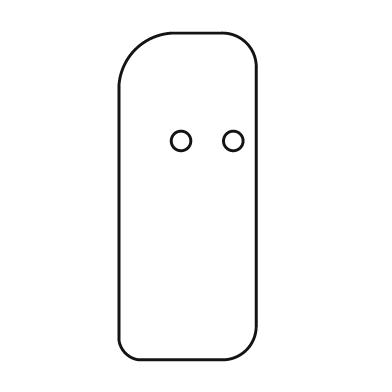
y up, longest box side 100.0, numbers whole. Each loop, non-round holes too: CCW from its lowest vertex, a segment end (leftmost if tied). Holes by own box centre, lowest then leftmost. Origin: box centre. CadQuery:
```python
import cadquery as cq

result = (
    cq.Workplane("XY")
    .moveTo(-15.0, -50.0)
    .lineTo(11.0, -50.0)
    .threePointArc((18.0, -47.0), (21.0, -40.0))
    .lineTo(21.0, 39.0)
    .threePointArc((18.0, 47.0), (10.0, 50.0))
    .lineTo(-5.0, 50.0)
    .threePointArc((-16.0, 45.0), (-21.0, 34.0))
    .lineTo(-21.0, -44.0)
    .threePointArc((-19.0, -48.0), (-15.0, -50.0))
    .close()
    .moveTo(-2.0, 17.0)
    .circle(3.0)
    .moveTo(14.0, 17.0)
    .circle(3.0)
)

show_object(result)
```